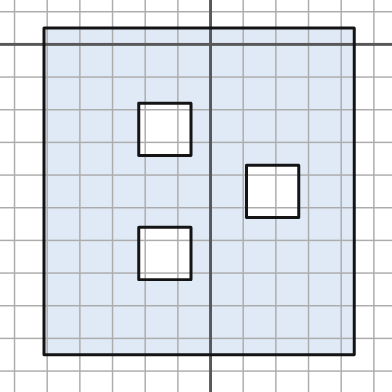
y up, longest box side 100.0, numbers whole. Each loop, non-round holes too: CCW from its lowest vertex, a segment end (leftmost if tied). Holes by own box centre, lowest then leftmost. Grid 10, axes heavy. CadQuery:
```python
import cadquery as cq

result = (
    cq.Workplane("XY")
    .moveTo(-51.0, -95.0)
    .lineTo(44.0, -95.0)
    .lineTo(44.0, 5.0)
    .lineTo(-51.0, 5.0)
    .close()
    .moveTo(-22.0, -72.0)
    .lineTo(-6.0, -72.0)
    .lineTo(-6.0, -56.0)
    .lineTo(-22.0, -56.0)
    .close()
    .moveTo(11.0, -53.0)
    .lineTo(27.0, -53.0)
    .lineTo(27.0, -37.0)
    .lineTo(11.0, -37.0)
    .close()
    .moveTo(-22.0, -34.0)
    .lineTo(-6.0, -34.0)
    .lineTo(-6.0, -18.0)
    .lineTo(-22.0, -18.0)
    .close()
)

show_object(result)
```